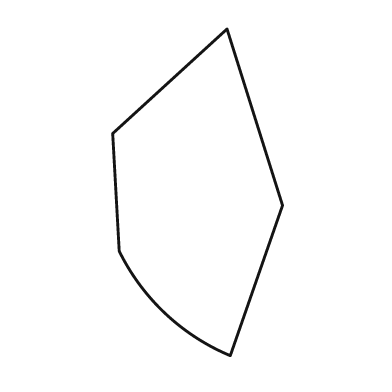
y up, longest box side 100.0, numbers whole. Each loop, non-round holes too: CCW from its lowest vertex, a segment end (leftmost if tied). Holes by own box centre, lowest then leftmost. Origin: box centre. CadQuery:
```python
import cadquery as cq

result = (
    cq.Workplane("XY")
    .moveTo(10.0, -50.0)
    .lineTo(26.0, -4.0)
    .lineTo(9.0, 50.0)
    .lineTo(-26.0, 18.0)
    .lineTo(-24.0, -18.0)
    .threePointArc((-10.0, -37.0), (10.0, -50.0))
    .close()
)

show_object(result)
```